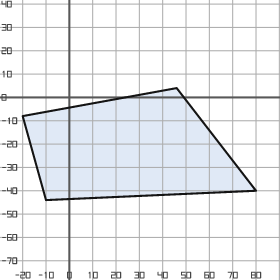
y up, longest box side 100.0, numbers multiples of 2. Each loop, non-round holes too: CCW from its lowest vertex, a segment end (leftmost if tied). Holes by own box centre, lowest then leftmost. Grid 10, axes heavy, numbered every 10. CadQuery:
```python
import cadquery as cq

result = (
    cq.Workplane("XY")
    .moveTo(-10.0, -44.0)
    .lineTo(80.0, -40.0)
    .lineTo(46.0, 4.0)
    .lineTo(-20.0, -8.0)
    .close()
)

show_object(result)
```